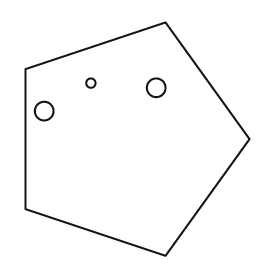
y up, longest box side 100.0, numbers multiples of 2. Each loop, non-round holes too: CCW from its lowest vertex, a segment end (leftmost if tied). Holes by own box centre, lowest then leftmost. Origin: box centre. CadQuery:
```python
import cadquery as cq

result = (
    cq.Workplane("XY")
    .moveTo(12.0, -50.0)
    .lineTo(48.0, 0.0)
    .lineTo(12.0, 50.0)
    .lineTo(-48.0, 30.0)
    .lineTo(-48.0, -30.0)
    .close()
    .moveTo(-40.0, 12.0)
    .circle(4.0)
    .moveTo(8.0, 22.0)
    .circle(4.0)
    .moveTo(-20.0, 24.0)
    .circle(2.0)
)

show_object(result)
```